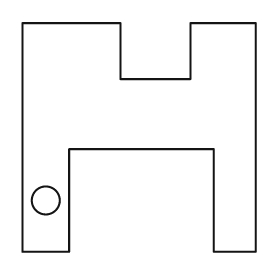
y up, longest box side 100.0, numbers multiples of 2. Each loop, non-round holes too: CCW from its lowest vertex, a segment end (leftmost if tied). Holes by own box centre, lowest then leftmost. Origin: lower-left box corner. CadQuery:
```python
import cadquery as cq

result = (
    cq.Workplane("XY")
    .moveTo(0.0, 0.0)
    .lineTo(20.0, 0.0)
    .lineTo(20.0, 44.0)
    .lineTo(82.0, 44.0)
    .lineTo(82.0, 0.0)
    .lineTo(100.0, 0.0)
    .lineTo(100.0, 98.0)
    .lineTo(72.0, 98.0)
    .lineTo(72.0, 74.0)
    .lineTo(42.0, 74.0)
    .lineTo(42.0, 98.0)
    .lineTo(0.0, 98.0)
    .close()
    .moveTo(10.0, 22.0)
    .circle(6.0)
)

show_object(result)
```